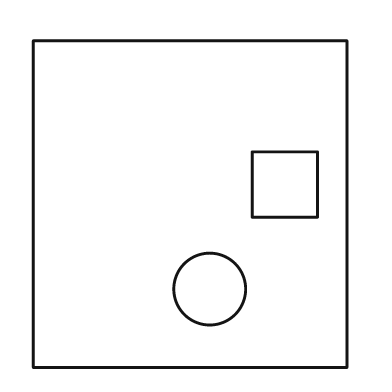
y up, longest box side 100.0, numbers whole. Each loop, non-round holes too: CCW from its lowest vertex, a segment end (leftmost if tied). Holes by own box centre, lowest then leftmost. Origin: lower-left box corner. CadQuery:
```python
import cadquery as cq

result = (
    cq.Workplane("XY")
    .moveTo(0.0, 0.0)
    .lineTo(96.0, 0.0)
    .lineTo(96.0, 100.0)
    .lineTo(0.0, 100.0)
    .close()
    .moveTo(54.0, 24.0)
    .circle(11.0)
    .moveTo(67.0, 46.0)
    .lineTo(87.0, 46.0)
    .lineTo(87.0, 66.0)
    .lineTo(67.0, 66.0)
    .close()
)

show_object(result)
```